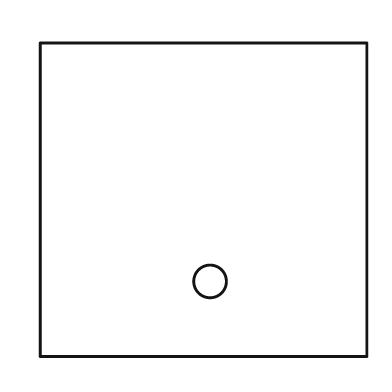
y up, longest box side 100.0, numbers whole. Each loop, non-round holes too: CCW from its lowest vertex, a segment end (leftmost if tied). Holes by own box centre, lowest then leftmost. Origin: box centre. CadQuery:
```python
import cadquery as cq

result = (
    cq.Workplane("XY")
    .moveTo(-50.0, -48.0)
    .lineTo(50.0, -48.0)
    .lineTo(50.0, 48.0)
    .lineTo(-50.0, 48.0)
    .close()
    .moveTo(2.0, -25.0)
    .circle(5.0)
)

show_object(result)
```